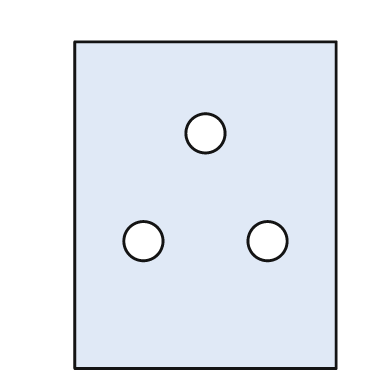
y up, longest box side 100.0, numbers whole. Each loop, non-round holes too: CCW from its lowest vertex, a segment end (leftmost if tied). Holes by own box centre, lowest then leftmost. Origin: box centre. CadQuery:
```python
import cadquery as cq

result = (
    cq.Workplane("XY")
    .moveTo(-40.0, -50.0)
    .lineTo(40.0, -50.0)
    .lineTo(40.0, 50.0)
    .lineTo(-40.0, 50.0)
    .close()
    .moveTo(-19.0, -11.0)
    .circle(6.0)
    .moveTo(19.0, -11.0)
    .circle(6.0)
    .moveTo(0.0, 22.0)
    .circle(6.0)
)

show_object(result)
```